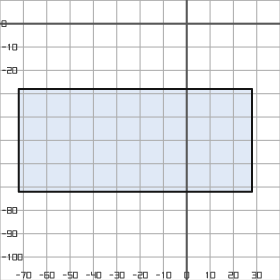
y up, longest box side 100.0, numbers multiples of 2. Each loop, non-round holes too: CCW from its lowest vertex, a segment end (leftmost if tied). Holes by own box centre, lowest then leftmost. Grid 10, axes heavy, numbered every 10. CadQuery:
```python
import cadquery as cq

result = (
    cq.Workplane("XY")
    .moveTo(-72.0, -72.0)
    .lineTo(28.0, -72.0)
    .lineTo(28.0, -28.0)
    .lineTo(-72.0, -28.0)
    .close()
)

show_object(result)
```